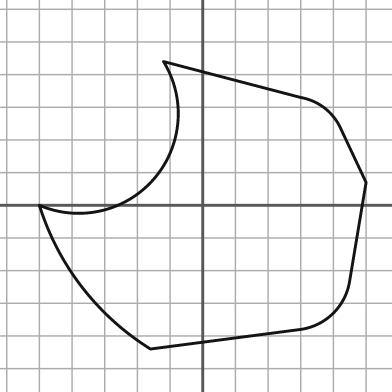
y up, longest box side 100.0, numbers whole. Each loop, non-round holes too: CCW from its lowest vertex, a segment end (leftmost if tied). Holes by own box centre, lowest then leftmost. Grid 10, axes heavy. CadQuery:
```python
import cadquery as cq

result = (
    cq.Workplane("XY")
    .moveTo(-16.0, -44.0)
    .lineTo(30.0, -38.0)
    .threePointArc((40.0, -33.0), (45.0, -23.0))
    .lineTo(50.0, 7.0)
    .lineTo(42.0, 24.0)
    .threePointArc((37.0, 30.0), (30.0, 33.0))
    .lineTo(-12.0, 44.0)
    .threePointArc((-15.0, 8.0), (-50.0, 0.0))
    .threePointArc((-37.0, -25.0), (-16.0, -44.0))
    .close()
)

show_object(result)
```